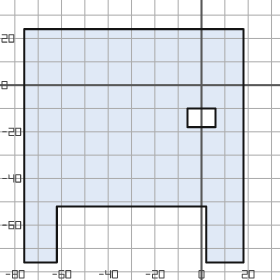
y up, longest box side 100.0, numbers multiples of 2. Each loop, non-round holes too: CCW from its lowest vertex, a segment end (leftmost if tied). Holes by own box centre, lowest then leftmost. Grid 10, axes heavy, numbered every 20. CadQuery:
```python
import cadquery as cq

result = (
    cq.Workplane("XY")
    .moveTo(-76.0, -76.0)
    .lineTo(-62.0, -76.0)
    .lineTo(-62.0, -52.0)
    .lineTo(2.0, -52.0)
    .lineTo(2.0, -76.0)
    .lineTo(18.0, -76.0)
    .lineTo(18.0, 24.0)
    .lineTo(-76.0, 24.0)
    .close()
    .moveTo(-6.0, -18.0)
    .lineTo(6.0, -18.0)
    .lineTo(6.0, -10.0)
    .lineTo(-6.0, -10.0)
    .close()
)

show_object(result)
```